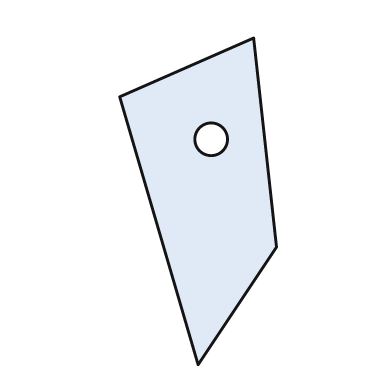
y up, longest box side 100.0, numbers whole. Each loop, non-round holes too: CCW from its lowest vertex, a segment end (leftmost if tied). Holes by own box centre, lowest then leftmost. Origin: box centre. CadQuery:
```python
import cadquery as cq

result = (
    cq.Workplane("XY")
    .moveTo(0.0, -50.0)
    .lineTo(24.0, -14.0)
    .lineTo(17.0, 50.0)
    .lineTo(-24.0, 32.0)
    .close()
    .moveTo(4.0, 19.0)
    .circle(5.0)
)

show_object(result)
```